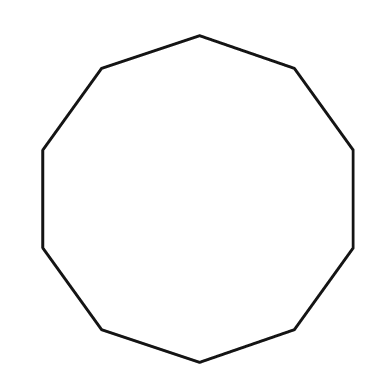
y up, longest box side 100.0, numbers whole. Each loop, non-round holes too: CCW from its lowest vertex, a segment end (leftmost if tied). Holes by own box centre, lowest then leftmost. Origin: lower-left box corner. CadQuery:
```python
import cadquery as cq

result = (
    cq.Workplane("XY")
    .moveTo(48.0, 0.0)
    .lineTo(77.0, 10.0)
    .lineTo(95.0, 35.0)
    .lineTo(95.0, 65.0)
    .lineTo(77.0, 90.0)
    .lineTo(48.0, 100.0)
    .lineTo(18.0, 90.0)
    .lineTo(0.0, 65.0)
    .lineTo(0.0, 35.0)
    .lineTo(18.0, 10.0)
    .close()
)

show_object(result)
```